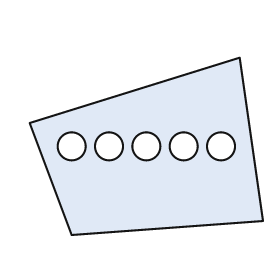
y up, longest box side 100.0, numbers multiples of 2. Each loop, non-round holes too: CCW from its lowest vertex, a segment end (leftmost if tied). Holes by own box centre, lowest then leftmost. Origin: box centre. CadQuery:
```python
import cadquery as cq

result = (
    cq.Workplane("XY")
    .moveTo(-32.0, -38.0)
    .lineTo(50.0, -32.0)
    .lineTo(40.0, 38.0)
    .lineTo(-50.0, 10.0)
    .close()
    .moveTo(-32.0, 0.0)
    .circle(6.0)
    .moveTo(-16.0, 0.0)
    .circle(6.0)
    .moveTo(0.0, 0.0)
    .circle(6.0)
    .moveTo(16.0, 0.0)
    .circle(6.0)
    .moveTo(32.0, 0.0)
    .circle(6.0)
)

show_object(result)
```